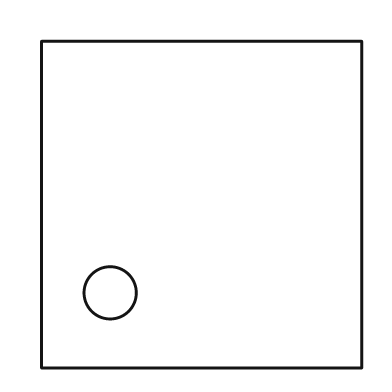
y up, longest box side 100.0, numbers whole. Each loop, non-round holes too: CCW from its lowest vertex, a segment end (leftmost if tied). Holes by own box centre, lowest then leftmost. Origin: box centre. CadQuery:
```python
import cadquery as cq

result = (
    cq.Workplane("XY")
    .moveTo(-49.0, -50.0)
    .lineTo(49.0, -50.0)
    .lineTo(49.0, 50.0)
    .lineTo(-49.0, 50.0)
    .close()
    .moveTo(-28.0, -27.0)
    .circle(8.0)
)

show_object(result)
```